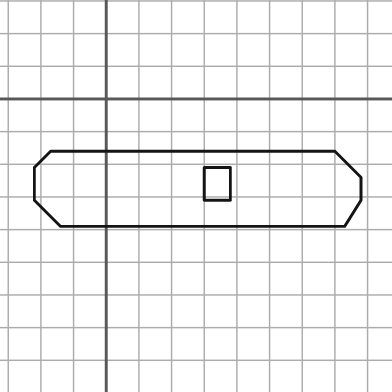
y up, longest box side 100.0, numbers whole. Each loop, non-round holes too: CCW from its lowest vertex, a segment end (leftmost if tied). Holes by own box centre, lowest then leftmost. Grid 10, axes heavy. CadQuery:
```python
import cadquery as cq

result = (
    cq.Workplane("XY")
    .moveTo(-14.0, -39.0)
    .lineTo(73.0, -39.0)
    .lineTo(78.0, -31.0)
    .lineTo(78.0, -24.0)
    .lineTo(70.0, -16.0)
    .lineTo(-17.0, -16.0)
    .lineTo(-22.0, -21.0)
    .lineTo(-22.0, -31.0)
    .close()
    .moveTo(30.0, -31.0)
    .lineTo(38.0, -31.0)
    .lineTo(38.0, -21.0)
    .lineTo(30.0, -21.0)
    .close()
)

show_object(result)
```